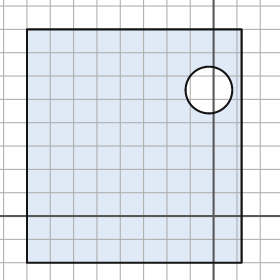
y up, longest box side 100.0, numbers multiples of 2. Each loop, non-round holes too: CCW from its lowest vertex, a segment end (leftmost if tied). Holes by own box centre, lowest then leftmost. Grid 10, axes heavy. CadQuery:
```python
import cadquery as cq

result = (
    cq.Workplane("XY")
    .moveTo(-80.0, -20.0)
    .lineTo(12.0, -20.0)
    .lineTo(12.0, 80.0)
    .lineTo(-80.0, 80.0)
    .close()
    .moveTo(-2.0, 54.0)
    .circle(10.0)
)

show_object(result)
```